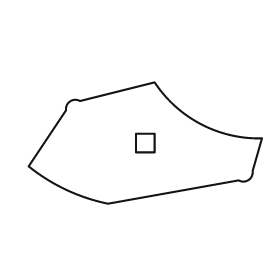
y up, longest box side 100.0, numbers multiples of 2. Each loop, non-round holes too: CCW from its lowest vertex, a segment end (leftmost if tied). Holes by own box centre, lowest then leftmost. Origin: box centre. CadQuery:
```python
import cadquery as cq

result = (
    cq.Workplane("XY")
    .moveTo(-16.0, -26.0)
    .lineTo(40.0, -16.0)
    .threePointArc((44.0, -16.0), (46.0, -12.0))
    .lineTo(50.0, 2.0)
    .threePointArc((24.0, 8.0), (4.0, 26.0))
    .lineTo(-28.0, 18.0)
    .threePointArc((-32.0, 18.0), (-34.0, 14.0))
    .lineTo(-50.0, -10.0)
    .threePointArc((-34.0, -20.0), (-16.0, -26.0))
    .close()
    .moveTo(-4.0, -4.0)
    .lineTo(4.0, -4.0)
    .lineTo(4.0, 4.0)
    .lineTo(-4.0, 4.0)
    .close()
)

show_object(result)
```